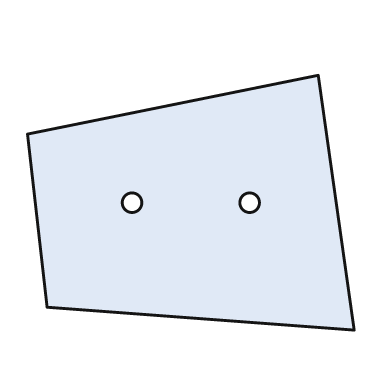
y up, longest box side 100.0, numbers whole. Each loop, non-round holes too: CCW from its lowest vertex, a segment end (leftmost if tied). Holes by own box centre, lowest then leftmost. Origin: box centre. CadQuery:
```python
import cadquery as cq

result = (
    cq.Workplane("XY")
    .moveTo(50.0, -39.0)
    .lineTo(39.0, 39.0)
    .lineTo(-50.0, 21.0)
    .lineTo(-44.0, -32.0)
    .close()
    .moveTo(-18.0, 0.0)
    .circle(3.0)
    .moveTo(18.0, 0.0)
    .circle(3.0)
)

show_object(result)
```